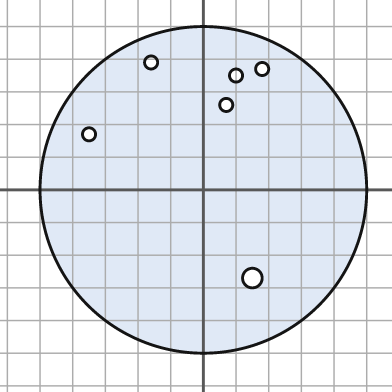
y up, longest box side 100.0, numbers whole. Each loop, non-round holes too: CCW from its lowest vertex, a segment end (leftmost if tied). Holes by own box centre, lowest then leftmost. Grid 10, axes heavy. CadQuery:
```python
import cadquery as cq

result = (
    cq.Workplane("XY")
    .moveTo(0.0, 0.0)
    .circle(50.0)
    .moveTo(15.0, -27.0)
    .circle(3.0)
    .moveTo(-35.0, 17.0)
    .circle(2.0)
    .moveTo(7.0, 26.0)
    .circle(2.0)
    .moveTo(10.0, 35.0)
    .circle(2.0)
    .moveTo(18.0, 37.0)
    .circle(2.0)
    .moveTo(-16.0, 39.0)
    .circle(2.0)
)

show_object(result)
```